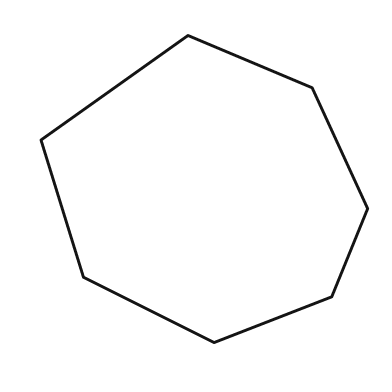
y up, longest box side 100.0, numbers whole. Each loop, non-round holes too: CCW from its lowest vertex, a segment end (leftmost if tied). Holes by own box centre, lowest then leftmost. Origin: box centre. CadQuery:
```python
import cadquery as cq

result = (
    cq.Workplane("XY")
    .moveTo(3.0, -47.0)
    .lineTo(39.0, -33.0)
    .lineTo(50.0, -6.0)
    .lineTo(33.0, 31.0)
    .lineTo(-5.0, 47.0)
    .lineTo(-50.0, 15.0)
    .lineTo(-37.0, -27.0)
    .close()
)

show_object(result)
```